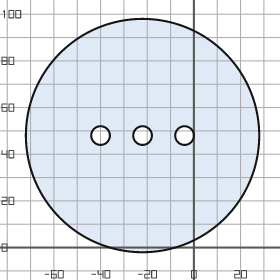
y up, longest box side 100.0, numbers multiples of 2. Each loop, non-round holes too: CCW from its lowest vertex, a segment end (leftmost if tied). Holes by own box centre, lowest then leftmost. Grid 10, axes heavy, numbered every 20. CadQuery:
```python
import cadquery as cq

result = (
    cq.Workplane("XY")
    .moveTo(-22.0, 48.0)
    .circle(50.0)
    .moveTo(-40.0, 48.0)
    .circle(4.0)
    .moveTo(-22.0, 48.0)
    .circle(4.0)
    .moveTo(-4.0, 48.0)
    .circle(4.0)
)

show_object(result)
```